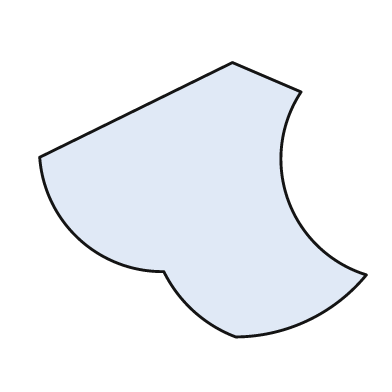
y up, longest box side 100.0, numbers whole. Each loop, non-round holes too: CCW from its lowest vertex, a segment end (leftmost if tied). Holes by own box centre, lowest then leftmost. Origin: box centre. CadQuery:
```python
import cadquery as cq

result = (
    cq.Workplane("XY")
    .moveTo(10.0, -42.0)
    .threePointArc((32.0, -37.0), (50.0, -23.0))
    .threePointArc((26.0, 0.0), (30.0, 33.0))
    .lineTo(9.0, 42.0)
    .lineTo(-50.0, 13.0)
    .threePointArc((-38.0, -12.0), (-12.0, -22.0))
    .threePointArc((-3.0, -34.0), (10.0, -42.0))
    .close()
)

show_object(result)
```